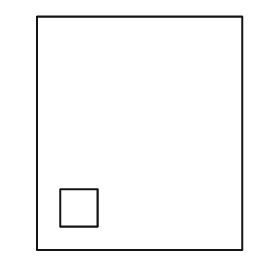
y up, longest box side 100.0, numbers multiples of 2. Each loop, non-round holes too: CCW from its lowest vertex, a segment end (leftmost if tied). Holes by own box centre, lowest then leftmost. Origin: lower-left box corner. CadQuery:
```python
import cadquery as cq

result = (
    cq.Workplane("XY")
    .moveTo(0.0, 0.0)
    .lineTo(88.0, 0.0)
    .lineTo(88.0, 100.0)
    .lineTo(0.0, 100.0)
    .close()
    .moveTo(10.0, 10.0)
    .lineTo(26.0, 10.0)
    .lineTo(26.0, 26.0)
    .lineTo(10.0, 26.0)
    .close()
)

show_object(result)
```